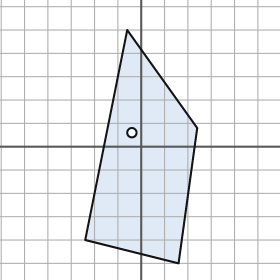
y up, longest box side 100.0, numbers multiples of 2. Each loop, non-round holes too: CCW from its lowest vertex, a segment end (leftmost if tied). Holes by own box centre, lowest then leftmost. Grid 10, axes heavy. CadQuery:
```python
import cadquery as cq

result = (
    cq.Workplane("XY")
    .moveTo(16.0, -50.0)
    .lineTo(24.0, 8.0)
    .lineTo(-6.0, 50.0)
    .lineTo(-24.0, -40.0)
    .close()
    .moveTo(-4.0, 6.0)
    .circle(2.0)
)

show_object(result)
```